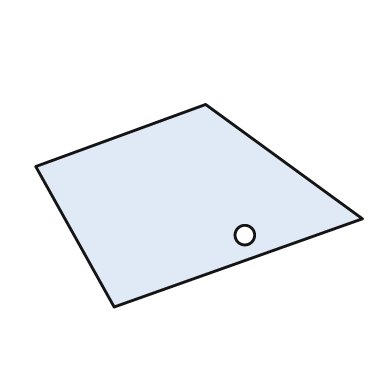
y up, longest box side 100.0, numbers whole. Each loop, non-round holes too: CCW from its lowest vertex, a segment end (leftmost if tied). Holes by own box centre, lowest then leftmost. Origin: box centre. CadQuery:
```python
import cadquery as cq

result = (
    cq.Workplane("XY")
    .moveTo(-26.0, -31.0)
    .lineTo(50.0, -4.0)
    .lineTo(2.0, 31.0)
    .lineTo(-50.0, 12.0)
    .close()
    .moveTo(14.0, -9.0)
    .circle(3.0)
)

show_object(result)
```